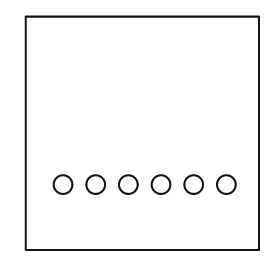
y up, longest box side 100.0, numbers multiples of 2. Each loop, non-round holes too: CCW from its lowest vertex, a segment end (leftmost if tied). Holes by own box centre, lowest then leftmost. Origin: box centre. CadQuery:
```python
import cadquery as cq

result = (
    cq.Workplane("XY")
    .moveTo(-50.0, -50.0)
    .lineTo(50.0, -50.0)
    .lineTo(50.0, 50.0)
    .lineTo(-50.0, 50.0)
    .close()
    .moveTo(-34.0, -22.0)
    .circle(4.0)
    .moveTo(-20.0, -22.0)
    .circle(4.0)
    .moveTo(-6.0, -22.0)
    .circle(4.0)
    .moveTo(8.0, -22.0)
    .circle(4.0)
    .moveTo(22.0, -22.0)
    .circle(4.0)
    .moveTo(36.0, -22.0)
    .circle(4.0)
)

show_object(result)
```